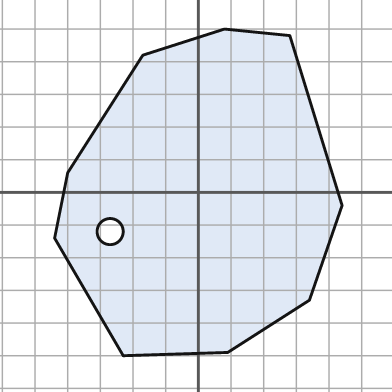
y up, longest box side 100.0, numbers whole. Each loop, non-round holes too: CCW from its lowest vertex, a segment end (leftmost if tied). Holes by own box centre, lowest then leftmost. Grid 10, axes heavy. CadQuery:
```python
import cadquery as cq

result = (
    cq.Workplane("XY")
    .moveTo(-23.0, -50.0)
    .lineTo(9.0, -49.0)
    .lineTo(34.0, -33.0)
    .lineTo(44.0, -4.0)
    .lineTo(28.0, 48.0)
    .lineTo(8.0, 50.0)
    .lineTo(-17.0, 42.0)
    .lineTo(-40.0, 6.0)
    .lineTo(-44.0, -14.0)
    .close()
    .moveTo(-27.0, -12.0)
    .circle(4.0)
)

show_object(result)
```